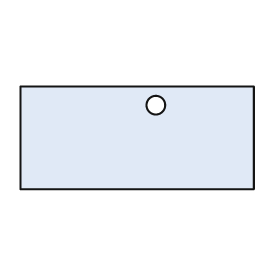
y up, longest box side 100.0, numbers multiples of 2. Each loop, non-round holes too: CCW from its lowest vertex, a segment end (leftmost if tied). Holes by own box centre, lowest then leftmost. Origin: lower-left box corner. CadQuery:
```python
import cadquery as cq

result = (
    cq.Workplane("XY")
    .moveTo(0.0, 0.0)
    .lineTo(100.0, 0.0)
    .lineTo(100.0, 44.0)
    .lineTo(0.0, 44.0)
    .close()
    .moveTo(58.0, 36.0)
    .circle(4.0)
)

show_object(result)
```